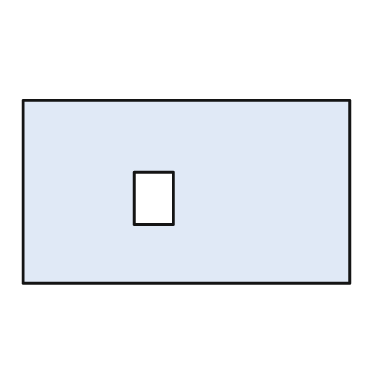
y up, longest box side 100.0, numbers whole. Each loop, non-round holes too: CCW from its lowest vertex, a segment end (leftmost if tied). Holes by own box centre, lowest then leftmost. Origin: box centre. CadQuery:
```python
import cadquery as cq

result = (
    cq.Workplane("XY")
    .moveTo(-50.0, -28.0)
    .lineTo(50.0, -28.0)
    .lineTo(50.0, 28.0)
    .lineTo(-50.0, 28.0)
    .close()
    .moveTo(-16.0, -10.0)
    .lineTo(-4.0, -10.0)
    .lineTo(-4.0, 6.0)
    .lineTo(-16.0, 6.0)
    .close()
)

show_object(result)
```